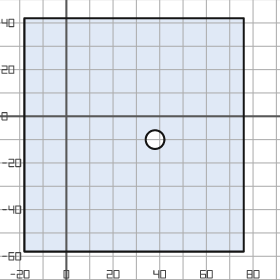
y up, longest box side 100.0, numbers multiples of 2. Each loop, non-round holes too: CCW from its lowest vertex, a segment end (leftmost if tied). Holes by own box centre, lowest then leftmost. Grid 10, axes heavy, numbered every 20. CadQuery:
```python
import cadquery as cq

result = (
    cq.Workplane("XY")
    .moveTo(-18.0, -58.0)
    .lineTo(76.0, -58.0)
    .lineTo(76.0, 42.0)
    .lineTo(-18.0, 42.0)
    .close()
    .moveTo(38.0, -10.0)
    .circle(4.0)
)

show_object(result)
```